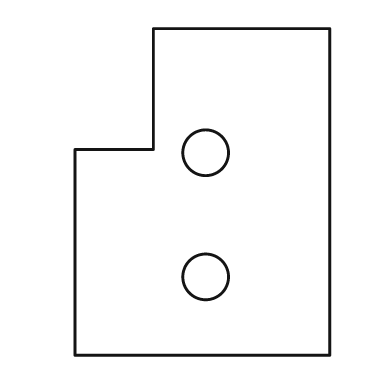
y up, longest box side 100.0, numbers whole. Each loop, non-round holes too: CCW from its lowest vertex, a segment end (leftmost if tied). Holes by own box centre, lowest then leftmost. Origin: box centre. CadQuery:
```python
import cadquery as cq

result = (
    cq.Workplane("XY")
    .moveTo(-39.0, -50.0)
    .lineTo(39.0, -50.0)
    .lineTo(39.0, 50.0)
    .lineTo(-15.0, 50.0)
    .lineTo(-15.0, 13.0)
    .lineTo(-39.0, 13.0)
    .close()
    .moveTo(1.0, -26.0)
    .circle(7.0)
    .moveTo(1.0, 12.0)
    .circle(7.0)
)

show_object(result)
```